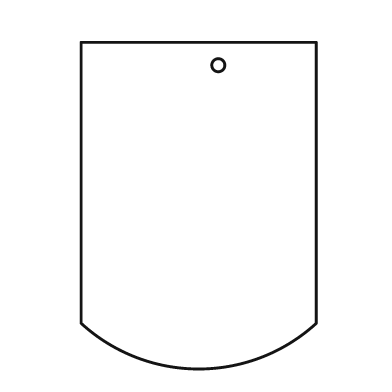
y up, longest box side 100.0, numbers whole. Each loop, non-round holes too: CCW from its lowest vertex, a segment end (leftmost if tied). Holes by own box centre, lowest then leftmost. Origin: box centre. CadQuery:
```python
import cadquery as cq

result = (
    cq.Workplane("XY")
    .moveTo(-36.0, -36.0)
    .threePointArc((0.0, -50.0), (36.0, -36.0))
    .lineTo(36.0, 50.0)
    .lineTo(-36.0, 50.0)
    .close()
    .moveTo(6.0, 43.0)
    .circle(2.0)
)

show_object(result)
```